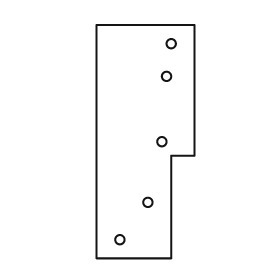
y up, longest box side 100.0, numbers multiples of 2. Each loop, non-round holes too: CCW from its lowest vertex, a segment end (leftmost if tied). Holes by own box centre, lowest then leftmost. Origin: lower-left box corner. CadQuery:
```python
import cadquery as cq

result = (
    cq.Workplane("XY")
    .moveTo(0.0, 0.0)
    .lineTo(32.0, 0.0)
    .lineTo(32.0, 44.0)
    .lineTo(42.0, 44.0)
    .lineTo(42.0, 100.0)
    .lineTo(0.0, 100.0)
    .close()
    .moveTo(10.0, 8.0)
    .circle(2.0)
    .moveTo(22.0, 24.0)
    .circle(2.0)
    .moveTo(28.0, 50.0)
    .circle(2.0)
    .moveTo(30.0, 78.0)
    .circle(2.0)
    .moveTo(32.0, 92.0)
    .circle(2.0)
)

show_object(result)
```